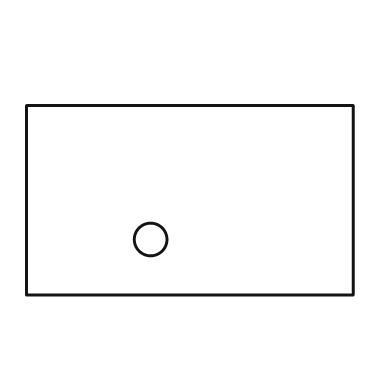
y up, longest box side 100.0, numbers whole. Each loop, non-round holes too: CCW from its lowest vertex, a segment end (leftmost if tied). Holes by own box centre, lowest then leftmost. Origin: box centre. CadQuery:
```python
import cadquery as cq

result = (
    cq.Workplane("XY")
    .moveTo(-50.0, -29.0)
    .lineTo(50.0, -29.0)
    .lineTo(50.0, 29.0)
    .lineTo(-50.0, 29.0)
    .close()
    .moveTo(-12.0, -12.0)
    .circle(5.0)
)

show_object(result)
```